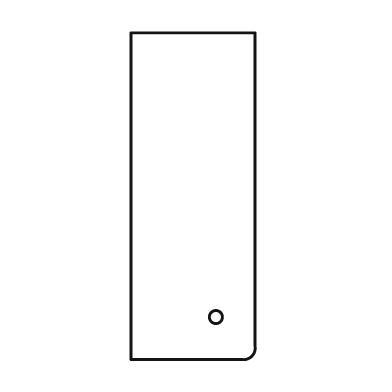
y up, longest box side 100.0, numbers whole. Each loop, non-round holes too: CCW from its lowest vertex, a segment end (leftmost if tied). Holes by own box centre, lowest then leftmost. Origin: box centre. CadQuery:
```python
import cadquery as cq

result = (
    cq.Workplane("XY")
    .moveTo(-19.0, -50.0)
    .lineTo(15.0, -50.0)
    .threePointArc((18.0, -49.0), (19.0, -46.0))
    .lineTo(19.0, 50.0)
    .lineTo(-19.0, 50.0)
    .close()
    .moveTo(7.0, -37.0)
    .circle(2.0)
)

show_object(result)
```